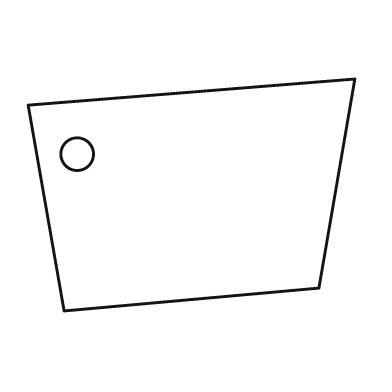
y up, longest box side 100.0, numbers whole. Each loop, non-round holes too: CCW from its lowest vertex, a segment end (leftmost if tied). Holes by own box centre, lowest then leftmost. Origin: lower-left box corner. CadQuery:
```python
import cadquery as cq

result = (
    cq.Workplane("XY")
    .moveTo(11.0, 0.0)
    .lineTo(89.0, 7.0)
    .lineTo(100.0, 71.0)
    .lineTo(0.0, 63.0)
    .close()
    .moveTo(15.0, 48.0)
    .circle(5.0)
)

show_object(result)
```